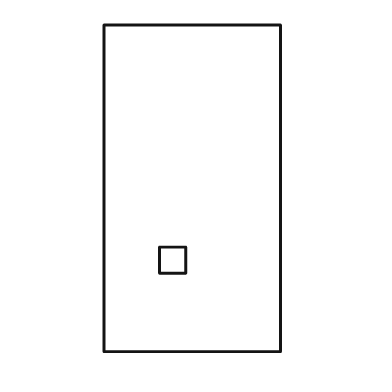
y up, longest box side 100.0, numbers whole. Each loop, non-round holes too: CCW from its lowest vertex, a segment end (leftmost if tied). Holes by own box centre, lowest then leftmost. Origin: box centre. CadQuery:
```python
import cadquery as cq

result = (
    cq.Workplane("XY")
    .moveTo(-27.0, -50.0)
    .lineTo(27.0, -50.0)
    .lineTo(27.0, 50.0)
    .lineTo(-27.0, 50.0)
    .close()
    .moveTo(-10.0, -26.0)
    .lineTo(-2.0, -26.0)
    .lineTo(-2.0, -18.0)
    .lineTo(-10.0, -18.0)
    .close()
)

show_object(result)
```